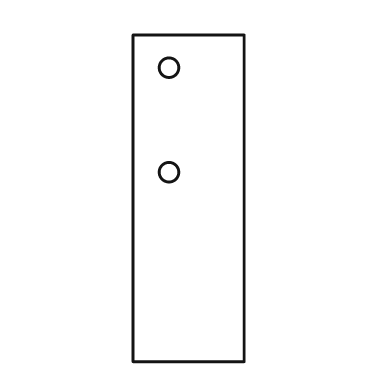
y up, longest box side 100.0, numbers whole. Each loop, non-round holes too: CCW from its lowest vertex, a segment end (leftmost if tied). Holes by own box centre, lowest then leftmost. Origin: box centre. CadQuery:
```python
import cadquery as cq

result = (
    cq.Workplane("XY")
    .moveTo(-17.0, -50.0)
    .lineTo(17.0, -50.0)
    .lineTo(17.0, 50.0)
    .lineTo(-17.0, 50.0)
    .close()
    .moveTo(-6.0, 8.0)
    .circle(3.0)
    .moveTo(-6.0, 40.0)
    .circle(3.0)
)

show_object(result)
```